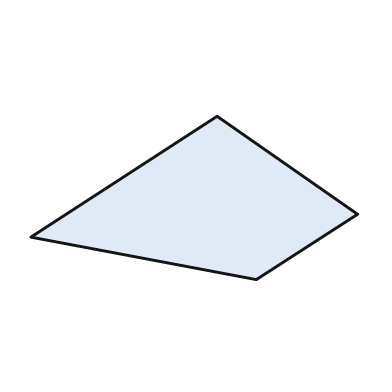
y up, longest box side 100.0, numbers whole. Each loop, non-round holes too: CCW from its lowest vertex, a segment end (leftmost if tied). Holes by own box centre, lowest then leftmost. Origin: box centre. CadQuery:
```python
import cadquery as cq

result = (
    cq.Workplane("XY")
    .moveTo(19.0, -25.0)
    .lineTo(50.0, -5.0)
    .lineTo(7.0, 25.0)
    .lineTo(-50.0, -12.0)
    .close()
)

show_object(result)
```